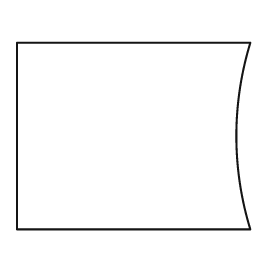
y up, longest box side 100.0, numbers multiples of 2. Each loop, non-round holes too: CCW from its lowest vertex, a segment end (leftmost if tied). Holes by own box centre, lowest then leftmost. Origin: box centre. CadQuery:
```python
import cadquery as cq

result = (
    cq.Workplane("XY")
    .moveTo(-50.0, -40.0)
    .lineTo(50.0, -40.0)
    .threePointArc((44.0, 0.0), (50.0, 40.0))
    .lineTo(-50.0, 40.0)
    .close()
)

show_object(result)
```